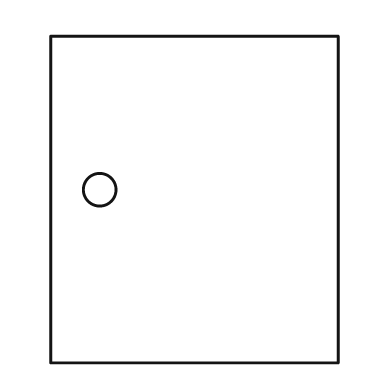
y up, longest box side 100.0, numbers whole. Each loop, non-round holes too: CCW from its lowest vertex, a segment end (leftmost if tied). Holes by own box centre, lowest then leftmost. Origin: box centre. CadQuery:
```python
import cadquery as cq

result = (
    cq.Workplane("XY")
    .moveTo(-44.0, -50.0)
    .lineTo(44.0, -50.0)
    .lineTo(44.0, 50.0)
    .lineTo(-44.0, 50.0)
    .close()
    .moveTo(-29.0, 3.0)
    .circle(5.0)
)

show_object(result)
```